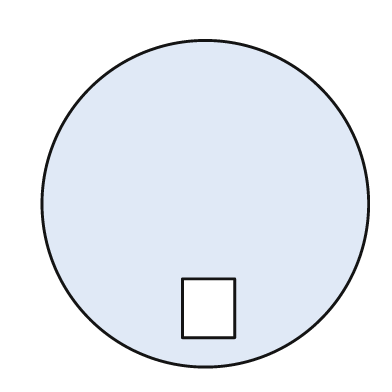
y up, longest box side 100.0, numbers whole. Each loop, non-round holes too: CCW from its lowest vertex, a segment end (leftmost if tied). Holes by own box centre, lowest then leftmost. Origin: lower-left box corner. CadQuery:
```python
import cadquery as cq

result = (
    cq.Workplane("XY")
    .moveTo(50.0, 50.0)
    .circle(50.0)
    .moveTo(43.0, 9.0)
    .lineTo(59.0, 9.0)
    .lineTo(59.0, 27.0)
    .lineTo(43.0, 27.0)
    .close()
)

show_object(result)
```